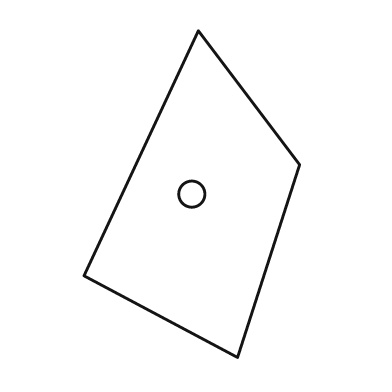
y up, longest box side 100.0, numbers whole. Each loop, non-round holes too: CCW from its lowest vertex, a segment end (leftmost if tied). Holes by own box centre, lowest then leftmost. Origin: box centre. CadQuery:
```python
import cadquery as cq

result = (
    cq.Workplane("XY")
    .moveTo(14.0, -50.0)
    .lineTo(33.0, 9.0)
    .lineTo(2.0, 50.0)
    .lineTo(-33.0, -25.0)
    .close()
    .moveTo(0.0, 0.0)
    .circle(4.0)
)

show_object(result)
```